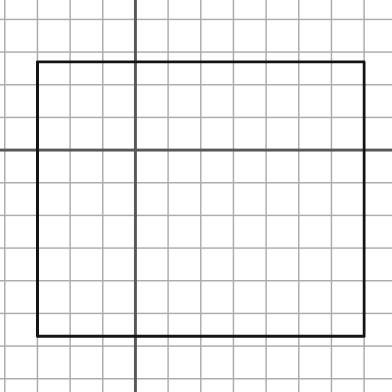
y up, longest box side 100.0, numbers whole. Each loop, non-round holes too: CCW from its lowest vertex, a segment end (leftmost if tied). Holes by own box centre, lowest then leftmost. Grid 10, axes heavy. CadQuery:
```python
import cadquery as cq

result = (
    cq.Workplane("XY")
    .moveTo(-30.0, -57.0)
    .lineTo(70.0, -57.0)
    .lineTo(70.0, 27.0)
    .lineTo(-30.0, 27.0)
    .close()
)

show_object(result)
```